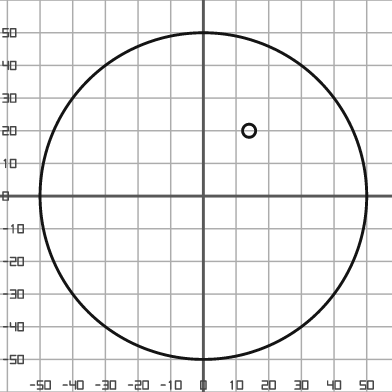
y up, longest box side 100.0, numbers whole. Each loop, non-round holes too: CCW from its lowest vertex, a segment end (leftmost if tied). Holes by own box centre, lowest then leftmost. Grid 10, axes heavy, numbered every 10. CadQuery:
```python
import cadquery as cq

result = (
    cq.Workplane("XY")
    .moveTo(0.0, 0.0)
    .circle(50.0)
    .moveTo(14.0, 20.0)
    .circle(2.0)
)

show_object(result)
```